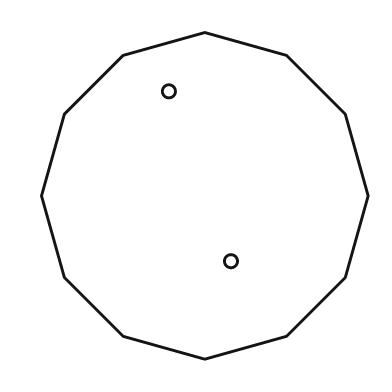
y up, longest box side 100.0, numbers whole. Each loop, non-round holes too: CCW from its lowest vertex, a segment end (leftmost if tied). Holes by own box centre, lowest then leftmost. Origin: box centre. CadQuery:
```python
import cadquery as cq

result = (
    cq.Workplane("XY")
    .moveTo(0.0, -50.0)
    .lineTo(25.0, -43.0)
    .lineTo(43.0, -25.0)
    .lineTo(50.0, 0.0)
    .lineTo(43.0, 25.0)
    .lineTo(25.0, 43.0)
    .lineTo(0.0, 50.0)
    .lineTo(-25.0, 43.0)
    .lineTo(-43.0, 25.0)
    .lineTo(-50.0, 0.0)
    .lineTo(-43.0, -25.0)
    .lineTo(-25.0, -43.0)
    .close()
    .moveTo(8.0, -20.0)
    .circle(2.0)
    .moveTo(-11.0, 32.0)
    .circle(2.0)
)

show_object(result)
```